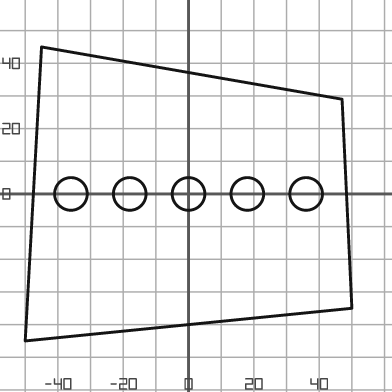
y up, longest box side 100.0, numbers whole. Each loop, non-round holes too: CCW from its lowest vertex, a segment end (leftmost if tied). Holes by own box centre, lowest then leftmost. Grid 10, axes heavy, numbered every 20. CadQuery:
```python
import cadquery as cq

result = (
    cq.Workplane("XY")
    .moveTo(-50.0, -45.0)
    .lineTo(50.0, -35.0)
    .lineTo(47.0, 29.0)
    .lineTo(-45.0, 45.0)
    .close()
    .moveTo(-36.0, 0.0)
    .circle(5.0)
    .moveTo(-18.0, 0.0)
    .circle(5.0)
    .moveTo(0.0, 0.0)
    .circle(5.0)
    .moveTo(18.0, 0.0)
    .circle(5.0)
    .moveTo(36.0, 0.0)
    .circle(5.0)
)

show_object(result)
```